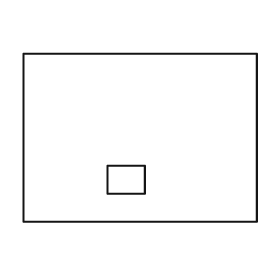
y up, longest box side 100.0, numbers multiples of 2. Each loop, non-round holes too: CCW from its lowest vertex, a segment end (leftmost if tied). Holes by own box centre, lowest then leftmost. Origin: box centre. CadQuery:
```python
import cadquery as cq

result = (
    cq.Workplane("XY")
    .moveTo(-50.0, -36.0)
    .lineTo(50.0, -36.0)
    .lineTo(50.0, 36.0)
    .lineTo(-50.0, 36.0)
    .close()
    .moveTo(-14.0, -24.0)
    .lineTo(2.0, -24.0)
    .lineTo(2.0, -12.0)
    .lineTo(-14.0, -12.0)
    .close()
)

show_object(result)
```